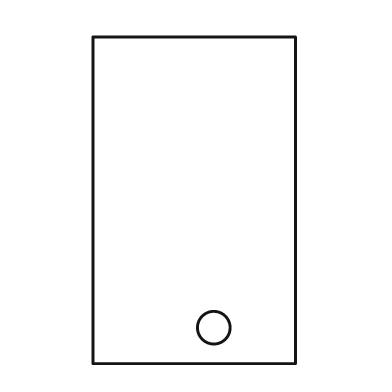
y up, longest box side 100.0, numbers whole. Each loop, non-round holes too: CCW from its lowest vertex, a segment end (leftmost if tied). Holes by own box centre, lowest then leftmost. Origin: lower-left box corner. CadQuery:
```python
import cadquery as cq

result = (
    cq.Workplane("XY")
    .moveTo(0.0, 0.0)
    .lineTo(62.0, 0.0)
    .lineTo(62.0, 100.0)
    .lineTo(0.0, 100.0)
    .close()
    .moveTo(37.0, 11.0)
    .circle(5.0)
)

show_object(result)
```